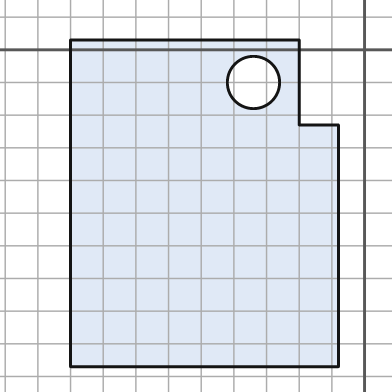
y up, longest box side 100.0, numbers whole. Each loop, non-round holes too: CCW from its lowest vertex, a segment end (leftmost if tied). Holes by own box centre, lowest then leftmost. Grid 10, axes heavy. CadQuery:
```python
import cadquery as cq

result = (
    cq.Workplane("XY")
    .moveTo(-90.0, -97.0)
    .lineTo(-8.0, -97.0)
    .lineTo(-8.0, -23.0)
    .lineTo(-20.0, -23.0)
    .lineTo(-20.0, 3.0)
    .lineTo(-90.0, 3.0)
    .close()
    .moveTo(-34.0, -10.0)
    .circle(8.0)
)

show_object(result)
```